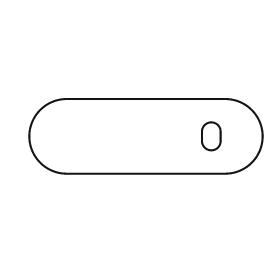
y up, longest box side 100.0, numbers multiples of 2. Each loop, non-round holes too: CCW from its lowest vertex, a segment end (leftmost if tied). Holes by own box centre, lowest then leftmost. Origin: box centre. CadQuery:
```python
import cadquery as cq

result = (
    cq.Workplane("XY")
    .moveTo(-34.0, -16.0)
    .lineTo(34.0, -16.0)
    .threePointArc((50.0, 0.0), (34.0, 16.0))
    .lineTo(-34.0, 16.0)
    .threePointArc((-50.0, 0.0), (-34.0, -16.0))
    .close()
    .moveTo(24.0, -2.0)
    .threePointArc((28.0, -6.0), (32.0, -2.0))
    .lineTo(32.0, 2.0)
    .threePointArc((28.0, 6.0), (24.0, 2.0))
    .close()
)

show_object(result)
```